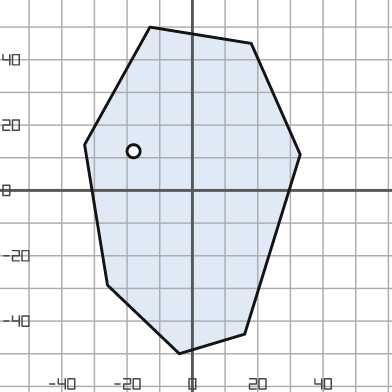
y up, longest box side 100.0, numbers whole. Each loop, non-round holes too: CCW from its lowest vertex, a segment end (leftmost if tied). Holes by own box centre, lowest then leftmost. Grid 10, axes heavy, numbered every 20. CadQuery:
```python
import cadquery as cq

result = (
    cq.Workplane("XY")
    .moveTo(-4.0, -50.0)
    .lineTo(16.0, -44.0)
    .lineTo(33.0, 11.0)
    .lineTo(18.0, 45.0)
    .lineTo(-13.0, 50.0)
    .lineTo(-33.0, 14.0)
    .lineTo(-26.0, -29.0)
    .close()
    .moveTo(-18.0, 12.0)
    .circle(2.0)
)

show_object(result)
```